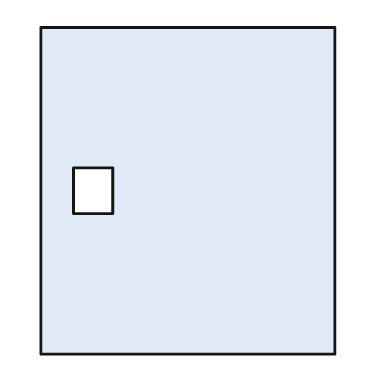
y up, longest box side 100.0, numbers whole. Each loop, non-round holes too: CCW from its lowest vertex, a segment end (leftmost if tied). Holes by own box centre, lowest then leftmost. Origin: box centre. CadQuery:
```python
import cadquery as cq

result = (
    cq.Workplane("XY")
    .moveTo(-45.0, -50.0)
    .lineTo(45.0, -50.0)
    .lineTo(45.0, 50.0)
    .lineTo(-45.0, 50.0)
    .close()
    .moveTo(-35.0, -7.0)
    .lineTo(-23.0, -7.0)
    .lineTo(-23.0, 7.0)
    .lineTo(-35.0, 7.0)
    .close()
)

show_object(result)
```